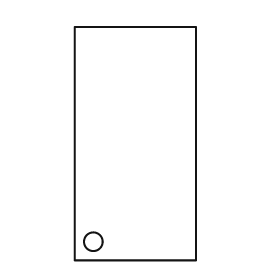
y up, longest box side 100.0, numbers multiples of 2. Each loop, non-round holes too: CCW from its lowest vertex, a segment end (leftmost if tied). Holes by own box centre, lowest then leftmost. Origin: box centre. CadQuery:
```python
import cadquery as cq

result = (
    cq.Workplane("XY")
    .moveTo(-26.0, -50.0)
    .lineTo(26.0, -50.0)
    .lineTo(26.0, 50.0)
    .lineTo(-26.0, 50.0)
    .close()
    .moveTo(-18.0, -42.0)
    .circle(4.0)
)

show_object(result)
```